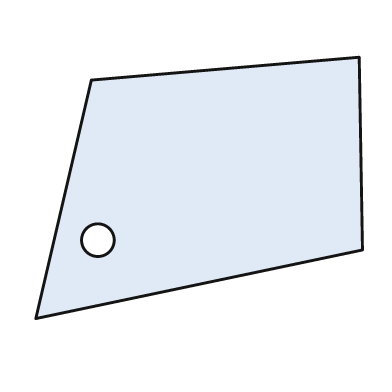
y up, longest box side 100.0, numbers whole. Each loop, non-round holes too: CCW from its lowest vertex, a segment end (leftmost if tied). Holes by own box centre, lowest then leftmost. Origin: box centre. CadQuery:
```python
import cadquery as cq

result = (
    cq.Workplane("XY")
    .moveTo(-50.0, -40.0)
    .lineTo(50.0, -19.0)
    .lineTo(49.0, 40.0)
    .lineTo(-33.0, 33.0)
    .close()
    .moveTo(-31.0, -16.0)
    .circle(5.0)
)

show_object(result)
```